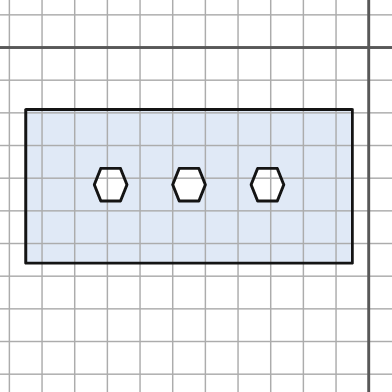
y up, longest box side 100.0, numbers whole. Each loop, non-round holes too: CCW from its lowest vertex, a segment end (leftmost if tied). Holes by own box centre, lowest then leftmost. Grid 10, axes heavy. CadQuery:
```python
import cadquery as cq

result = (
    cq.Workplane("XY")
    .moveTo(-105.0, -66.0)
    .lineTo(-5.0, -66.0)
    .lineTo(-5.0, -19.0)
    .lineTo(-105.0, -19.0)
    .close()
    .moveTo(-82.0, -47.0)
    .lineTo(-76.0, -47.0)
    .lineTo(-74.0, -42.0)
    .lineTo(-76.0, -37.0)
    .lineTo(-82.0, -37.0)
    .lineTo(-84.0, -42.0)
    .close()
    .moveTo(-58.0, -47.0)
    .lineTo(-52.0, -47.0)
    .lineTo(-50.0, -42.0)
    .lineTo(-52.0, -37.0)
    .lineTo(-58.0, -37.0)
    .lineTo(-60.0, -42.0)
    .close()
    .moveTo(-34.0, -47.0)
    .lineTo(-28.0, -47.0)
    .lineTo(-26.0, -42.0)
    .lineTo(-28.0, -37.0)
    .lineTo(-34.0, -37.0)
    .lineTo(-36.0, -42.0)
    .close()
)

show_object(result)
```